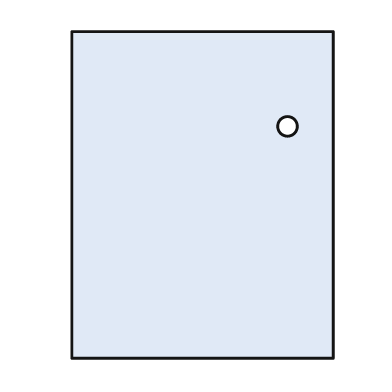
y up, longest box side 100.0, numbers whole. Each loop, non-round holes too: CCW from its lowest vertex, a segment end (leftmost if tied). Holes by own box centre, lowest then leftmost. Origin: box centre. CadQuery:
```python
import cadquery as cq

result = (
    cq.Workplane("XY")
    .moveTo(-40.0, -50.0)
    .lineTo(40.0, -50.0)
    .lineTo(40.0, 50.0)
    .lineTo(-40.0, 50.0)
    .close()
    .moveTo(26.0, 21.0)
    .circle(3.0)
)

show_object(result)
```